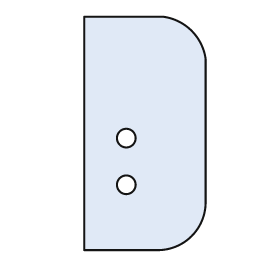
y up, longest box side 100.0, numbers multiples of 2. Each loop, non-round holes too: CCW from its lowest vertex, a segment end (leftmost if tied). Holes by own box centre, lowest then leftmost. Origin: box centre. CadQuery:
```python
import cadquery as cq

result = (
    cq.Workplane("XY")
    .moveTo(-26.0, -50.0)
    .lineTo(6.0, -50.0)
    .threePointArc((20.0, -44.0), (26.0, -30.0))
    .lineTo(26.0, 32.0)
    .threePointArc((20.0, 44.0), (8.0, 50.0))
    .lineTo(-26.0, 50.0)
    .close()
    .moveTo(-8.0, -22.0)
    .circle(4.0)
    .moveTo(-8.0, -2.0)
    .circle(4.0)
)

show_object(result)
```